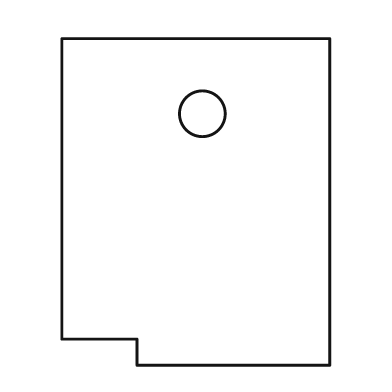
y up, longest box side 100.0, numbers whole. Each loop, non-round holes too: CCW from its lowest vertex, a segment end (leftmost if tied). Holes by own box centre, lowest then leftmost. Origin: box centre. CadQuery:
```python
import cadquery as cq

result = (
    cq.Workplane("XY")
    .moveTo(-18.0, -50.0)
    .lineTo(41.0, -50.0)
    .lineTo(41.0, 50.0)
    .lineTo(-41.0, 50.0)
    .lineTo(-41.0, -42.0)
    .lineTo(-18.0, -42.0)
    .close()
    .moveTo(2.0, 27.0)
    .circle(7.0)
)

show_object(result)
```